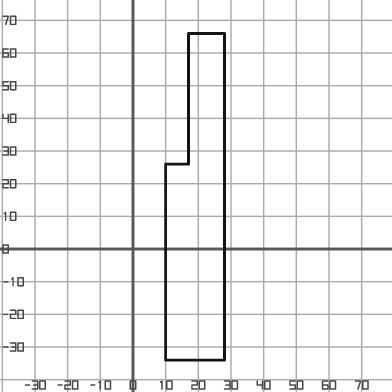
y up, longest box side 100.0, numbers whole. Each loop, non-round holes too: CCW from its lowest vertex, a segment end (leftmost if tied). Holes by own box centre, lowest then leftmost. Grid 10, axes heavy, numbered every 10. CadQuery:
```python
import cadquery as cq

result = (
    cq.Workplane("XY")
    .moveTo(10.0, -34.0)
    .lineTo(28.0, -34.0)
    .lineTo(28.0, 66.0)
    .lineTo(17.0, 66.0)
    .lineTo(17.0, 26.0)
    .lineTo(10.0, 26.0)
    .close()
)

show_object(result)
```